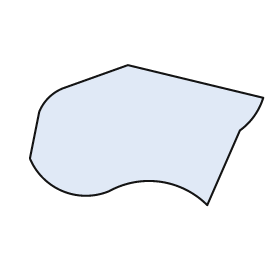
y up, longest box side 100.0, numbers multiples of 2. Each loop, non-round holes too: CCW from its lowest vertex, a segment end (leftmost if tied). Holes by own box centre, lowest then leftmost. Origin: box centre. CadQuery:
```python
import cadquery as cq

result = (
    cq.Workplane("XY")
    .moveTo(26.0, -30.0)
    .lineTo(40.0, 2.0)
    .threePointArc((46.0, 8.0), (50.0, 16.0))
    .lineTo(-8.0, 30.0)
    .lineTo(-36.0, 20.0)
    .threePointArc((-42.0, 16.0), (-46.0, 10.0))
    .lineTo(-50.0, -10.0)
    .threePointArc((-36.0, -24.0), (-16.0, -24.0))
    .threePointArc((6.0, -20.0), (26.0, -30.0))
    .close()
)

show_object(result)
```